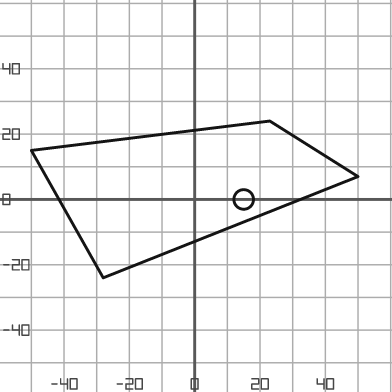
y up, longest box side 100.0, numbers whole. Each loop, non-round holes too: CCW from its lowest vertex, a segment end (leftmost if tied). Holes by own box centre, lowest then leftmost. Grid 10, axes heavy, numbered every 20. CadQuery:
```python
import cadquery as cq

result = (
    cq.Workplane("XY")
    .moveTo(-28.0, -24.0)
    .lineTo(50.0, 7.0)
    .lineTo(23.0, 24.0)
    .lineTo(-50.0, 15.0)
    .close()
    .moveTo(15.0, 0.0)
    .circle(3.0)
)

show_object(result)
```